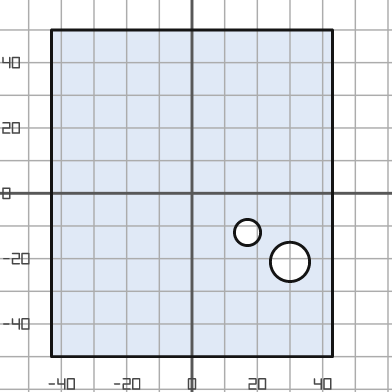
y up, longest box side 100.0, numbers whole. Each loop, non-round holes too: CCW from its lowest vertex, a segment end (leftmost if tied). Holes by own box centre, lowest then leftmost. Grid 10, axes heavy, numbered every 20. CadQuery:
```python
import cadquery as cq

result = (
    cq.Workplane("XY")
    .moveTo(-43.0, -50.0)
    .lineTo(43.0, -50.0)
    .lineTo(43.0, 50.0)
    .lineTo(-43.0, 50.0)
    .close()
    .moveTo(30.0, -21.0)
    .circle(6.0)
    .moveTo(17.0, -12.0)
    .circle(4.0)
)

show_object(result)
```